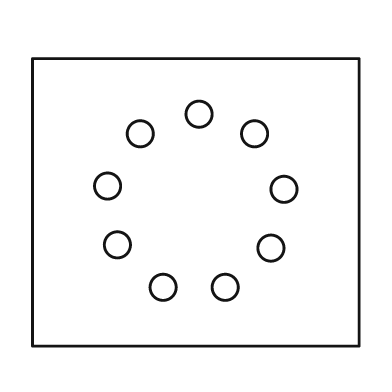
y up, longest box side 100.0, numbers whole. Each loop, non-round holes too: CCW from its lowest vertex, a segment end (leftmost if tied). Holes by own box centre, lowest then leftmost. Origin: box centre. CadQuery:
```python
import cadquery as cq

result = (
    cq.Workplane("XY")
    .moveTo(-50.0, -44.0)
    .lineTo(50.0, -44.0)
    .lineTo(50.0, 44.0)
    .lineTo(-50.0, 44.0)
    .close()
    .moveTo(-10.0, -26.0)
    .circle(4.0)
    .moveTo(9.0, -26.0)
    .circle(4.0)
    .moveTo(23.0, -14.0)
    .circle(4.0)
    .moveTo(-24.0, -13.0)
    .circle(4.0)
    .moveTo(27.0, 4.0)
    .circle(4.0)
    .moveTo(-27.0, 5.0)
    .circle(4.0)
    .moveTo(-17.0, 21.0)
    .circle(4.0)
    .moveTo(18.0, 21.0)
    .circle(4.0)
    .moveTo(1.0, 27.0)
    .circle(4.0)
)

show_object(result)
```